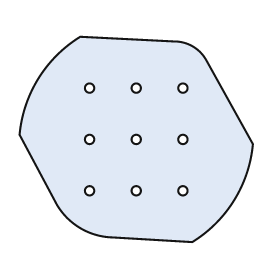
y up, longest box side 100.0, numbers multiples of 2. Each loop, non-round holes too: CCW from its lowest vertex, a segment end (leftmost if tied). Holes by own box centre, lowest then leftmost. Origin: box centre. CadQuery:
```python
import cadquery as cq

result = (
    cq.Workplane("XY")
    .moveTo(24.0, -44.0)
    .threePointArc((42.0, -26.0), (50.0, -2.0))
    .lineTo(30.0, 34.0)
    .threePointArc((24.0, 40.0), (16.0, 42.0))
    .lineTo(-24.0, 44.0)
    .threePointArc((-42.0, 26.0), (-50.0, 2.0))
    .lineTo(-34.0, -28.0)
    .threePointArc((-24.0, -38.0), (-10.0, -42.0))
    .close()
    .moveTo(-20.0, -22.0)
    .circle(2.0)
    .moveTo(0.0, -22.0)
    .circle(2.0)
    .moveTo(20.0, -22.0)
    .circle(2.0)
    .moveTo(-20.0, 0.0)
    .circle(2.0)
    .moveTo(0.0, 0.0)
    .circle(2.0)
    .moveTo(20.0, 0.0)
    .circle(2.0)
    .moveTo(-20.0, 22.0)
    .circle(2.0)
    .moveTo(0.0, 22.0)
    .circle(2.0)
    .moveTo(20.0, 22.0)
    .circle(2.0)
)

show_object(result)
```